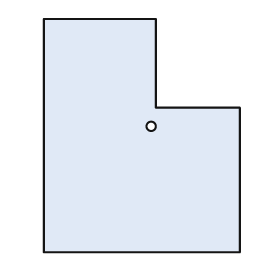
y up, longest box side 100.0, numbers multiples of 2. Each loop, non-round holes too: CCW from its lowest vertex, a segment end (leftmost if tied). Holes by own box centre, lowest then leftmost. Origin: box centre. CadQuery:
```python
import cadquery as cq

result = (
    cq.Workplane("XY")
    .moveTo(-42.0, -50.0)
    .lineTo(42.0, -50.0)
    .lineTo(42.0, 12.0)
    .lineTo(6.0, 12.0)
    .lineTo(6.0, 50.0)
    .lineTo(-42.0, 50.0)
    .close()
    .moveTo(4.0, 4.0)
    .circle(2.0)
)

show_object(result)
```